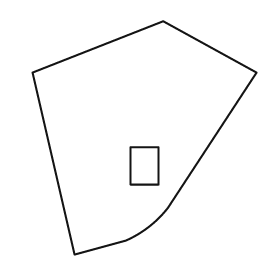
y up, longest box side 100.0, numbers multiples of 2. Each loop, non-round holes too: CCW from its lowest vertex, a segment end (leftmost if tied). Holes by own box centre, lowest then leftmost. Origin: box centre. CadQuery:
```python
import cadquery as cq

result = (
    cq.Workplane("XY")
    .moveTo(-30.0, -50.0)
    .lineTo(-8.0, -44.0)
    .threePointArc((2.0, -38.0), (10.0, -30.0))
    .lineTo(48.0, 28.0)
    .lineTo(8.0, 50.0)
    .lineTo(-48.0, 28.0)
    .close()
    .moveTo(-6.0, -20.0)
    .lineTo(6.0, -20.0)
    .lineTo(6.0, -4.0)
    .lineTo(-6.0, -4.0)
    .close()
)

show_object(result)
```